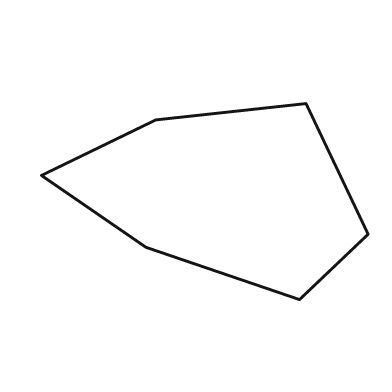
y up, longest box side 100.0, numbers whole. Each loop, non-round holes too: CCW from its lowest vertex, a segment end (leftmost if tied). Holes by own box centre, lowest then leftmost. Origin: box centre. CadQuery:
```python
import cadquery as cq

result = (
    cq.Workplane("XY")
    .moveTo(29.0, -30.0)
    .lineTo(50.0, -10.0)
    .lineTo(31.0, 30.0)
    .lineTo(-15.0, 25.0)
    .lineTo(-50.0, 8.0)
    .lineTo(-18.0, -14.0)
    .close()
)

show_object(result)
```